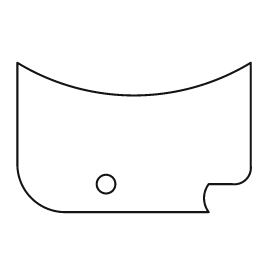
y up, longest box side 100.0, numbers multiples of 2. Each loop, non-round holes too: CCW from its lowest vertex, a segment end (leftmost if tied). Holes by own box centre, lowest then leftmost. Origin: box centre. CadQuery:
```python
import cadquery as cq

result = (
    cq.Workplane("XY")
    .moveTo(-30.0, -32.0)
    .lineTo(32.0, -32.0)
    .threePointArc((30.0, -26.0), (32.0, -20.0))
    .lineTo(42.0, -20.0)
    .threePointArc((48.0, -18.0), (50.0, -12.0))
    .lineTo(50.0, 32.0)
    .threePointArc((0.0, 18.0), (-50.0, 32.0))
    .lineTo(-50.0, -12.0)
    .threePointArc((-44.0, -26.0), (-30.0, -32.0))
    .close()
    .moveTo(-12.0, -20.0)
    .circle(4.0)
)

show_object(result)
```